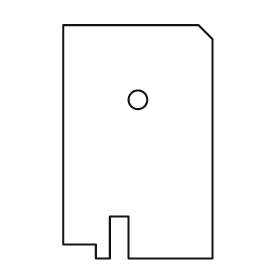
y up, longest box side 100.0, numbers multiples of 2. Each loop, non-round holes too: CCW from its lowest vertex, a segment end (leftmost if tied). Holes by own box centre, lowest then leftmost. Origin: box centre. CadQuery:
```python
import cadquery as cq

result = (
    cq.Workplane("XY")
    .moveTo(-18.0, -50.0)
    .lineTo(-12.0, -50.0)
    .lineTo(-12.0, -32.0)
    .lineTo(-4.0, -32.0)
    .lineTo(-4.0, -50.0)
    .lineTo(32.0, -50.0)
    .lineTo(32.0, 44.0)
    .lineTo(26.0, 50.0)
    .lineTo(-32.0, 50.0)
    .lineTo(-32.0, -44.0)
    .lineTo(-18.0, -44.0)
    .close()
    .moveTo(0.0, 18.0)
    .circle(4.0)
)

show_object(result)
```